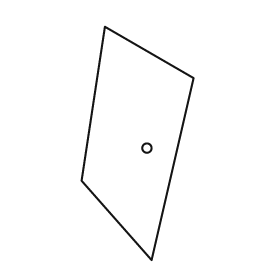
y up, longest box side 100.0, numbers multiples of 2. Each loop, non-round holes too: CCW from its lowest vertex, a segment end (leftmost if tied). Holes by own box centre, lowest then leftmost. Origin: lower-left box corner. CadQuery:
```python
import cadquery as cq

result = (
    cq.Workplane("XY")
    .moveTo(30.0, 0.0)
    .lineTo(48.0, 78.0)
    .lineTo(10.0, 100.0)
    .lineTo(0.0, 34.0)
    .close()
    .moveTo(28.0, 48.0)
    .circle(2.0)
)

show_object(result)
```